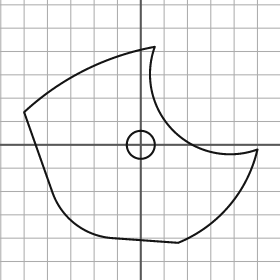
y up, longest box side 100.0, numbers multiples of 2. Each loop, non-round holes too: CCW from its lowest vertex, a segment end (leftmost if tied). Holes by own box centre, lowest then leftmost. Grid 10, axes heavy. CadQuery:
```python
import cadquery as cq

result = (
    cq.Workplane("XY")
    .moveTo(16.0, -42.0)
    .threePointArc((38.0, -26.0), (50.0, -2.0))
    .threePointArc((14.0, 6.0), (6.0, 42.0))
    .threePointArc((-24.0, 32.0), (-50.0, 14.0))
    .lineTo(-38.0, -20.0)
    .threePointArc((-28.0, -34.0), (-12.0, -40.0))
    .close()
    .moveTo(0.0, 0.0)
    .circle(6.0)
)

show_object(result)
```